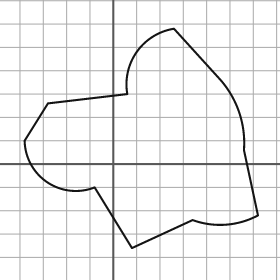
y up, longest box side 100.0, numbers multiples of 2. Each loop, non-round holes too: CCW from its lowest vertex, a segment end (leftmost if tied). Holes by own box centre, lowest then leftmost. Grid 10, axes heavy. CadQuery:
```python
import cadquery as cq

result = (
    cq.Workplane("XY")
    .moveTo(8.0, -36.0)
    .lineTo(34.0, -24.0)
    .threePointArc((48.0, -26.0), (62.0, -22.0))
    .lineTo(56.0, 6.0)
    .threePointArc((54.0, 22.0), (46.0, 36.0))
    .lineTo(26.0, 58.0)
    .threePointArc((10.0, 48.0), (6.0, 30.0))
    .lineTo(-28.0, 26.0)
    .lineTo(-38.0, 10.0)
    .threePointArc((-28.0, -8.0), (-8.0, -10.0))
    .close()
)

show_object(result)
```